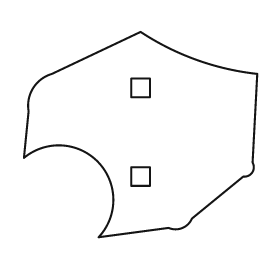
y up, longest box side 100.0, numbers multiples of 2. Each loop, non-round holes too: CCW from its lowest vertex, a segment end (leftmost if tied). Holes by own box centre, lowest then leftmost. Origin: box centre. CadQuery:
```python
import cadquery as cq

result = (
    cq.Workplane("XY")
    .moveTo(-18.0, -44.0)
    .lineTo(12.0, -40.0)
    .threePointArc((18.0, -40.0), (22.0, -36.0))
    .lineTo(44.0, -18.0)
    .threePointArc((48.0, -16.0), (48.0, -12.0))
    .lineTo(50.0, 26.0)
    .threePointArc((24.0, 32.0), (0.0, 44.0))
    .lineTo(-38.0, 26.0)
    .threePointArc((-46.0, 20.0), (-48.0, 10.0))
    .lineTo(-50.0, -10.0)
    .threePointArc((-18.0, -12.0), (-18.0, -44.0))
    .close()
    .moveTo(-4.0, -22.0)
    .lineTo(4.0, -22.0)
    .lineTo(4.0, -14.0)
    .lineTo(-4.0, -14.0)
    .close()
    .moveTo(-4.0, 16.0)
    .lineTo(4.0, 16.0)
    .lineTo(4.0, 24.0)
    .lineTo(-4.0, 24.0)
    .close()
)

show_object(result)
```